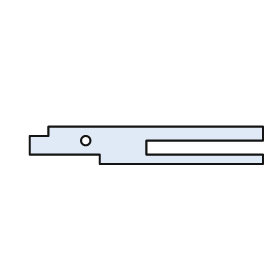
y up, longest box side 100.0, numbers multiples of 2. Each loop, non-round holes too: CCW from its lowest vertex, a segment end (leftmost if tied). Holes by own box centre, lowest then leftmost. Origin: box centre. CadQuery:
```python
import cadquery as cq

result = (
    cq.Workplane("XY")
    .moveTo(-20.0, -8.0)
    .lineTo(50.0, -8.0)
    .lineTo(50.0, -4.0)
    .lineTo(0.0, -4.0)
    .lineTo(0.0, 2.0)
    .lineTo(50.0, 2.0)
    .lineTo(50.0, 8.0)
    .lineTo(-42.0, 8.0)
    .lineTo(-42.0, 4.0)
    .lineTo(-50.0, 4.0)
    .lineTo(-50.0, -4.0)
    .lineTo(-20.0, -4.0)
    .close()
    .moveTo(-26.0, 2.0)
    .circle(2.0)
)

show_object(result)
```